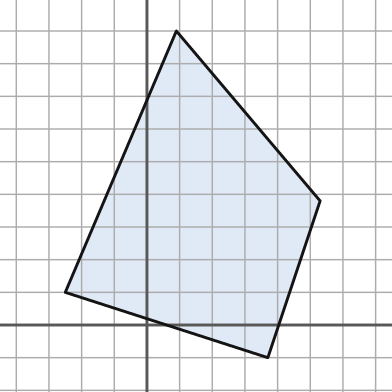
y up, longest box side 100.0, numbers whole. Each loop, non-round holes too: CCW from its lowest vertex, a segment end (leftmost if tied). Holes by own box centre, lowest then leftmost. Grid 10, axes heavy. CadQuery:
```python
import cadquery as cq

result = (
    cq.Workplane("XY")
    .moveTo(37.0, -10.0)
    .lineTo(53.0, 38.0)
    .lineTo(9.0, 90.0)
    .lineTo(-25.0, 10.0)
    .close()
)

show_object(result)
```